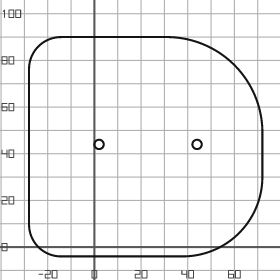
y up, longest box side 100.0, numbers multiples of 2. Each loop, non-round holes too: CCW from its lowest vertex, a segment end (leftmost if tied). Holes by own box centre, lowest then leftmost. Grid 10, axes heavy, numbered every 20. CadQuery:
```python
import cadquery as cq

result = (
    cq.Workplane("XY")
    .moveTo(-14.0, -4.0)
    .lineTo(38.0, -4.0)
    .threePointArc((62.0, 6.0), (72.0, 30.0))
    .lineTo(72.0, 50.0)
    .threePointArc((60.0, 78.0), (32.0, 90.0))
    .lineTo(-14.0, 90.0)
    .threePointArc((-24.0, 86.0), (-28.0, 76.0))
    .lineTo(-28.0, 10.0)
    .threePointArc((-24.0, 0.0), (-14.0, -4.0))
    .close()
    .moveTo(2.0, 44.0)
    .circle(2.0)
    .moveTo(44.0, 44.0)
    .circle(2.0)
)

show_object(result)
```